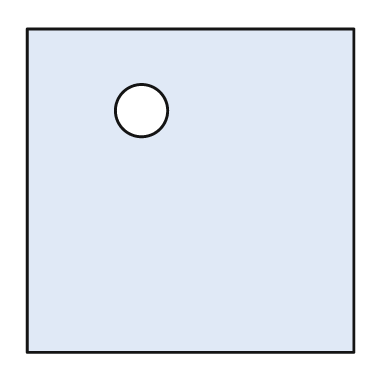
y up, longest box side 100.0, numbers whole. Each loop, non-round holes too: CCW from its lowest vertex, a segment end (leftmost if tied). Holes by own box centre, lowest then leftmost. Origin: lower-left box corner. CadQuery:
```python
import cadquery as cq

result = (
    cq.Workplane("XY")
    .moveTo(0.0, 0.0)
    .lineTo(100.0, 0.0)
    .lineTo(100.0, 99.0)
    .lineTo(0.0, 99.0)
    .close()
    .moveTo(35.0, 74.0)
    .circle(8.0)
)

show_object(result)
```